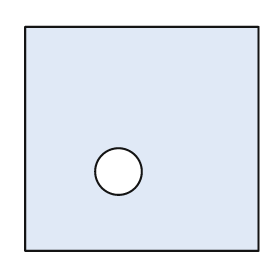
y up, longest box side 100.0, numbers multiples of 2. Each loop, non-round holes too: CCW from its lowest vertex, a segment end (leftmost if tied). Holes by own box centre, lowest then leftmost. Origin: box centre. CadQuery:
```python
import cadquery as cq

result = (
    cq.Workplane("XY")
    .moveTo(-50.0, -48.0)
    .lineTo(50.0, -48.0)
    .lineTo(50.0, 48.0)
    .lineTo(-50.0, 48.0)
    .close()
    .moveTo(-10.0, -14.0)
    .circle(10.0)
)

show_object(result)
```